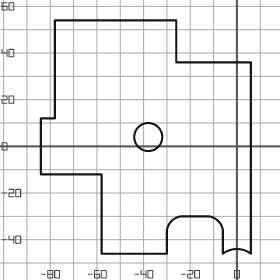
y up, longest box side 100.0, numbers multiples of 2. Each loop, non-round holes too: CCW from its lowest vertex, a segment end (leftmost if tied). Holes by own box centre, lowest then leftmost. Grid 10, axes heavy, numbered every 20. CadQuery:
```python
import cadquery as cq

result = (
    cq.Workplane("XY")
    .moveTo(-58.0, -46.0)
    .lineTo(-30.0, -46.0)
    .lineTo(-30.0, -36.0)
    .threePointArc((-28.0, -32.0), (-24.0, -30.0))
    .lineTo(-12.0, -30.0)
    .threePointArc((-8.0, -32.0), (-6.0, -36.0))
    .lineTo(-6.0, -46.0)
    .threePointArc((0.0, -44.0), (6.0, -46.0))
    .lineTo(6.0, 36.0)
    .lineTo(-26.0, 36.0)
    .lineTo(-26.0, 54.0)
    .lineTo(-78.0, 54.0)
    .lineTo(-78.0, 12.0)
    .lineTo(-84.0, 12.0)
    .lineTo(-84.0, -12.0)
    .lineTo(-58.0, -12.0)
    .close()
    .moveTo(-38.0, 4.0)
    .circle(6.0)
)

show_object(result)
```